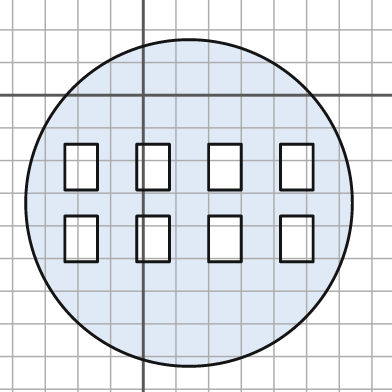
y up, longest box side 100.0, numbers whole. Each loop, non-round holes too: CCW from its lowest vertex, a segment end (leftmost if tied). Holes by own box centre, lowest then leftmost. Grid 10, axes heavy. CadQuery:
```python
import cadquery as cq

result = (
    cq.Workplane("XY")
    .moveTo(14.0, -33.0)
    .circle(50.0)
    .moveTo(-24.0, -51.0)
    .lineTo(-14.0, -51.0)
    .lineTo(-14.0, -37.0)
    .lineTo(-24.0, -37.0)
    .close()
    .moveTo(-2.0, -51.0)
    .lineTo(8.0, -51.0)
    .lineTo(8.0, -37.0)
    .lineTo(-2.0, -37.0)
    .close()
    .moveTo(20.0, -51.0)
    .lineTo(30.0, -51.0)
    .lineTo(30.0, -37.0)
    .lineTo(20.0, -37.0)
    .close()
    .moveTo(42.0, -51.0)
    .lineTo(52.0, -51.0)
    .lineTo(52.0, -37.0)
    .lineTo(42.0, -37.0)
    .close()
    .moveTo(-24.0, -29.0)
    .lineTo(-14.0, -29.0)
    .lineTo(-14.0, -15.0)
    .lineTo(-24.0, -15.0)
    .close()
    .moveTo(-2.0, -29.0)
    .lineTo(8.0, -29.0)
    .lineTo(8.0, -15.0)
    .lineTo(-2.0, -15.0)
    .close()
    .moveTo(20.0, -29.0)
    .lineTo(30.0, -29.0)
    .lineTo(30.0, -15.0)
    .lineTo(20.0, -15.0)
    .close()
    .moveTo(42.0, -29.0)
    .lineTo(52.0, -29.0)
    .lineTo(52.0, -15.0)
    .lineTo(42.0, -15.0)
    .close()
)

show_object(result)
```